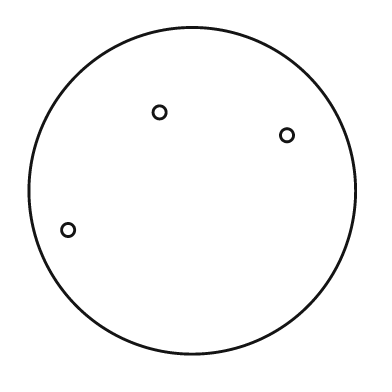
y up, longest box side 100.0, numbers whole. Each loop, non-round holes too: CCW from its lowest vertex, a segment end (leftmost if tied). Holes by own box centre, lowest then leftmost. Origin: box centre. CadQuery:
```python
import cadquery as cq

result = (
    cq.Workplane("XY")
    .moveTo(0.0, 0.0)
    .circle(50.0)
    .moveTo(-38.0, -12.0)
    .circle(2.0)
    .moveTo(29.0, 17.0)
    .circle(2.0)
    .moveTo(-10.0, 24.0)
    .circle(2.0)
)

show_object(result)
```